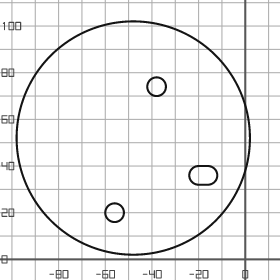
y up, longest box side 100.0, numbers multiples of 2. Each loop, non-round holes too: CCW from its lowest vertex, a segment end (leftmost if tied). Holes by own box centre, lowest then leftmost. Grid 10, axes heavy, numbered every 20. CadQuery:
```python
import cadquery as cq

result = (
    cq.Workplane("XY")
    .moveTo(-48.0, 52.0)
    .circle(50.0)
    .moveTo(-56.0, 20.0)
    .circle(4.0)
    .moveTo(-20.0, 32.0)
    .lineTo(-16.0, 32.0)
    .threePointArc((-12.0, 36.0), (-16.0, 40.0))
    .lineTo(-20.0, 40.0)
    .threePointArc((-24.0, 36.0), (-20.0, 32.0))
    .close()
    .moveTo(-38.0, 74.0)
    .circle(4.0)
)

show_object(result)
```